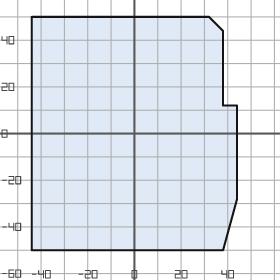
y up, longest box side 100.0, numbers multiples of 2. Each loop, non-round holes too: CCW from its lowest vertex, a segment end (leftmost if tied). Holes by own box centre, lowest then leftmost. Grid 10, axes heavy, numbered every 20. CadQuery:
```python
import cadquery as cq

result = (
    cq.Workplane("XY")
    .moveTo(-44.0, -50.0)
    .lineTo(38.0, -50.0)
    .lineTo(44.0, -28.0)
    .lineTo(44.0, 12.0)
    .lineTo(38.0, 12.0)
    .lineTo(38.0, 44.0)
    .lineTo(32.0, 50.0)
    .lineTo(-44.0, 50.0)
    .close()
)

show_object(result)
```